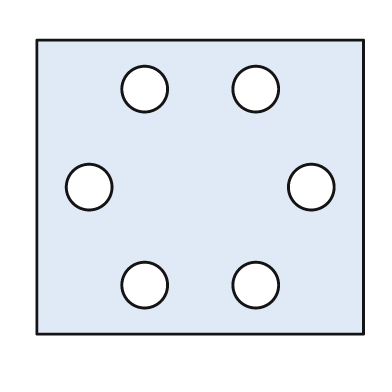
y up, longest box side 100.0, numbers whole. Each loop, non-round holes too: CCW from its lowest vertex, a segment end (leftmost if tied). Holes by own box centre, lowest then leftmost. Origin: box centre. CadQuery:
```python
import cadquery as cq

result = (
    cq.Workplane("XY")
    .moveTo(-50.0, -45.0)
    .lineTo(50.0, -45.0)
    .lineTo(50.0, 45.0)
    .lineTo(-50.0, 45.0)
    .close()
    .moveTo(-17.0, -30.0)
    .circle(7.0)
    .moveTo(17.0, -30.0)
    .circle(7.0)
    .moveTo(-34.0, 0.0)
    .circle(7.0)
    .moveTo(34.0, 0.0)
    .circle(7.0)
    .moveTo(-17.0, 30.0)
    .circle(7.0)
    .moveTo(17.0, 30.0)
    .circle(7.0)
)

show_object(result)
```